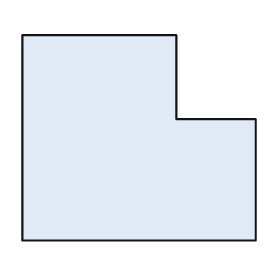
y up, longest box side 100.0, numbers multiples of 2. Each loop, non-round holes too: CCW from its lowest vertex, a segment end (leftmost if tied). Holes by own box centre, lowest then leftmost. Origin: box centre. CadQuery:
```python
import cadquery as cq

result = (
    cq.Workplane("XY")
    .moveTo(-50.0, -44.0)
    .lineTo(50.0, -44.0)
    .lineTo(50.0, 8.0)
    .lineTo(16.0, 8.0)
    .lineTo(16.0, 44.0)
    .lineTo(-50.0, 44.0)
    .close()
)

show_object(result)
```